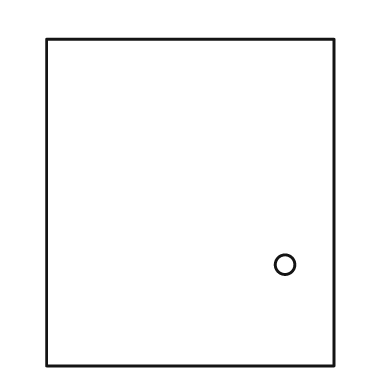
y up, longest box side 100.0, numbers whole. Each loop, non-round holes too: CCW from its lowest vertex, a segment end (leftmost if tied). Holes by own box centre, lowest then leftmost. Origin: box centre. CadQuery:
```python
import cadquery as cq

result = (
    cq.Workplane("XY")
    .moveTo(-44.0, -50.0)
    .lineTo(44.0, -50.0)
    .lineTo(44.0, 50.0)
    .lineTo(-44.0, 50.0)
    .close()
    .moveTo(29.0, -19.0)
    .circle(3.0)
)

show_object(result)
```